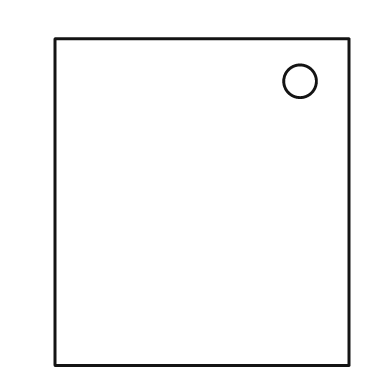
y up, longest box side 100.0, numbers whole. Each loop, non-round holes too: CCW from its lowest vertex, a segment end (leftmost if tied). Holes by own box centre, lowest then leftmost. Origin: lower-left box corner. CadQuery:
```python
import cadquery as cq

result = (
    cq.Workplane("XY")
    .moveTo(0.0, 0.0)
    .lineTo(90.0, 0.0)
    .lineTo(90.0, 100.0)
    .lineTo(0.0, 100.0)
    .close()
    .moveTo(75.0, 87.0)
    .circle(5.0)
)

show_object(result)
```